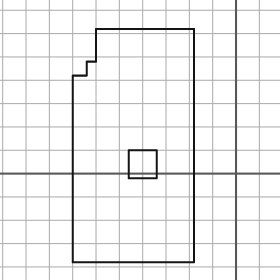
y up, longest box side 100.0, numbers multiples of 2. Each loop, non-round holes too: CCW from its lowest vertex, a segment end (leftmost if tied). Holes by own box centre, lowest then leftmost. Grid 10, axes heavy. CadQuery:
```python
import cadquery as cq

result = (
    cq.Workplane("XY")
    .moveTo(-70.0, -38.0)
    .lineTo(-18.0, -38.0)
    .lineTo(-18.0, 62.0)
    .lineTo(-60.0, 62.0)
    .lineTo(-60.0, 48.0)
    .lineTo(-64.0, 48.0)
    .lineTo(-64.0, 42.0)
    .lineTo(-70.0, 42.0)
    .close()
    .moveTo(-46.0, -2.0)
    .lineTo(-34.0, -2.0)
    .lineTo(-34.0, 10.0)
    .lineTo(-46.0, 10.0)
    .close()
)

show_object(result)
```